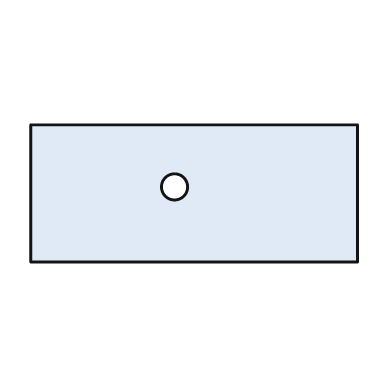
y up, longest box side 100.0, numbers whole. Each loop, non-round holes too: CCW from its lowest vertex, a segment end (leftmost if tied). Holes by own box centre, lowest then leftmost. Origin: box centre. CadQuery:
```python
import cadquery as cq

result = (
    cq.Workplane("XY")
    .moveTo(-50.0, -21.0)
    .lineTo(50.0, -21.0)
    .lineTo(50.0, 21.0)
    .lineTo(-50.0, 21.0)
    .close()
    .moveTo(-6.0, 2.0)
    .circle(4.0)
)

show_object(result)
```